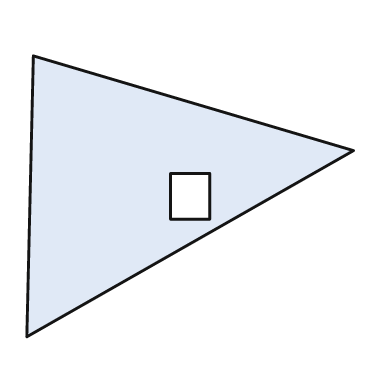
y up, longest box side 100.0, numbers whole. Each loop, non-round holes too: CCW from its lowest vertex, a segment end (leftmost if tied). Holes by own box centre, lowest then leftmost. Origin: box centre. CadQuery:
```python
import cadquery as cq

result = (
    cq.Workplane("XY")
    .moveTo(-50.0, -43.0)
    .lineTo(50.0, 14.0)
    .lineTo(-48.0, 43.0)
    .close()
    .moveTo(-6.0, -7.0)
    .lineTo(6.0, -7.0)
    .lineTo(6.0, 7.0)
    .lineTo(-6.0, 7.0)
    .close()
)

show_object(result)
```